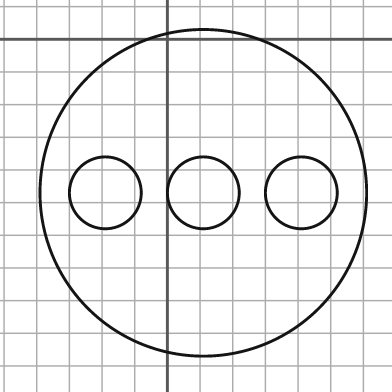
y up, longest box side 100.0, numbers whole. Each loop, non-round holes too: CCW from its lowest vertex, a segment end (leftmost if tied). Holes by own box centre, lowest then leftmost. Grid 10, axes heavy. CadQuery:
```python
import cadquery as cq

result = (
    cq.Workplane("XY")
    .moveTo(11.0, -47.0)
    .circle(50.0)
    .moveTo(-19.0, -47.0)
    .circle(11.0)
    .moveTo(11.0, -47.0)
    .circle(11.0)
    .moveTo(41.0, -47.0)
    .circle(11.0)
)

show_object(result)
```